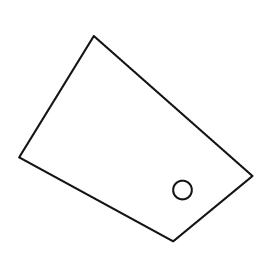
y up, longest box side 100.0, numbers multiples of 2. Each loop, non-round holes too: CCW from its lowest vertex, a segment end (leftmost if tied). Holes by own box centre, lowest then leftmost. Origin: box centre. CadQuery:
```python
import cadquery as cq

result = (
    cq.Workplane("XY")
    .moveTo(16.0, -44.0)
    .lineTo(50.0, -16.0)
    .lineTo(-18.0, 44.0)
    .lineTo(-50.0, -8.0)
    .close()
    .moveTo(20.0, -22.0)
    .circle(4.0)
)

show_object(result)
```